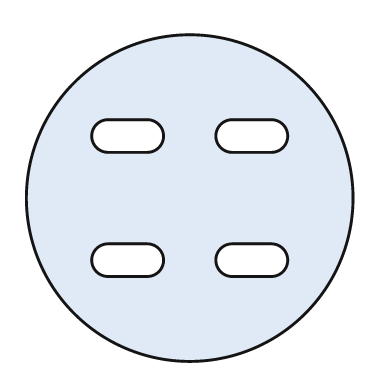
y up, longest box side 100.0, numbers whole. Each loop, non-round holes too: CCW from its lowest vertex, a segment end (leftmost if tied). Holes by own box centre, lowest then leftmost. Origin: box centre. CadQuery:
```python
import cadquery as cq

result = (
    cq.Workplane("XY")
    .moveTo(0.0, 0.0)
    .circle(50.0)
    .moveTo(-25.0, -24.0)
    .lineTo(-13.0, -24.0)
    .threePointArc((-8.0, -19.0), (-13.0, -14.0))
    .lineTo(-25.0, -14.0)
    .threePointArc((-30.0, -19.0), (-25.0, -24.0))
    .close()
    .moveTo(13.0, -24.0)
    .lineTo(25.0, -24.0)
    .threePointArc((30.0, -19.0), (25.0, -14.0))
    .lineTo(13.0, -14.0)
    .threePointArc((8.0, -19.0), (13.0, -24.0))
    .close()
    .moveTo(-25.0, 14.0)
    .lineTo(-13.0, 14.0)
    .threePointArc((-8.0, 19.0), (-13.0, 24.0))
    .lineTo(-25.0, 24.0)
    .threePointArc((-30.0, 19.0), (-25.0, 14.0))
    .close()
    .moveTo(13.0, 14.0)
    .lineTo(25.0, 14.0)
    .threePointArc((30.0, 19.0), (25.0, 24.0))
    .lineTo(13.0, 24.0)
    .threePointArc((8.0, 19.0), (13.0, 14.0))
    .close()
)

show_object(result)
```